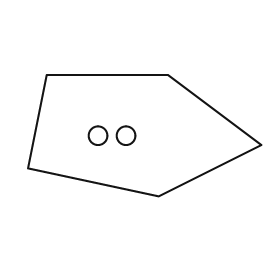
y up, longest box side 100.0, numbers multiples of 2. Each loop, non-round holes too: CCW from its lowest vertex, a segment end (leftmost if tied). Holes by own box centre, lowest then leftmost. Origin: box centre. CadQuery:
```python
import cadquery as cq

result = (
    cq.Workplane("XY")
    .moveTo(6.0, -26.0)
    .lineTo(50.0, -4.0)
    .lineTo(10.0, 26.0)
    .lineTo(-42.0, 26.0)
    .lineTo(-50.0, -14.0)
    .close()
    .moveTo(-20.0, 0.0)
    .circle(4.0)
    .moveTo(-8.0, 0.0)
    .circle(4.0)
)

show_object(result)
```